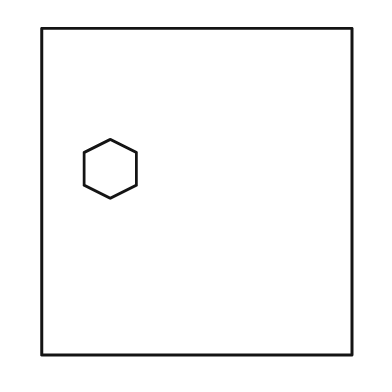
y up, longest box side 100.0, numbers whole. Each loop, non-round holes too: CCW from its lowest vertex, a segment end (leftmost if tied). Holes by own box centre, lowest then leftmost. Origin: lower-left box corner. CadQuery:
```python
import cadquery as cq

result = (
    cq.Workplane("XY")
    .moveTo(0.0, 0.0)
    .lineTo(95.0, 0.0)
    .lineTo(95.0, 100.0)
    .lineTo(0.0, 100.0)
    .close()
    .moveTo(21.0, 48.0)
    .lineTo(29.0, 52.0)
    .lineTo(29.0, 62.0)
    .lineTo(21.0, 66.0)
    .lineTo(13.0, 62.0)
    .lineTo(13.0, 52.0)
    .close()
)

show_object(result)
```